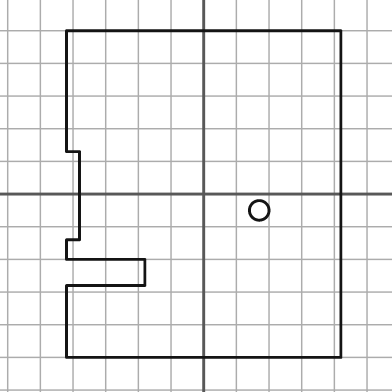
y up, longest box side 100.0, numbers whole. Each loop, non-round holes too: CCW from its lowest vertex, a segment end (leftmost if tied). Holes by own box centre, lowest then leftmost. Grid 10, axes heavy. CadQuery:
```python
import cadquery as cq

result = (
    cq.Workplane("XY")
    .moveTo(-42.0, -50.0)
    .lineTo(42.0, -50.0)
    .lineTo(42.0, 50.0)
    .lineTo(-42.0, 50.0)
    .lineTo(-42.0, 13.0)
    .lineTo(-38.0, 13.0)
    .lineTo(-38.0, -14.0)
    .lineTo(-42.0, -14.0)
    .lineTo(-42.0, -20.0)
    .lineTo(-18.0, -20.0)
    .lineTo(-18.0, -28.0)
    .lineTo(-42.0, -28.0)
    .close()
    .moveTo(17.0, -5.0)
    .circle(3.0)
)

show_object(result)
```